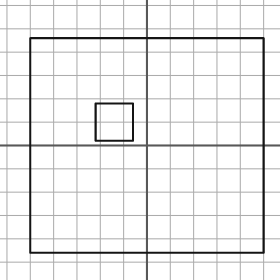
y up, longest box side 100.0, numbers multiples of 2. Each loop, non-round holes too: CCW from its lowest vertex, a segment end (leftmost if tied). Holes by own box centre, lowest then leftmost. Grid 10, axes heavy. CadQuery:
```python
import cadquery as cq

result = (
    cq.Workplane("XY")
    .moveTo(-50.0, -46.0)
    .lineTo(50.0, -46.0)
    .lineTo(50.0, 46.0)
    .lineTo(-50.0, 46.0)
    .close()
    .moveTo(-22.0, 2.0)
    .lineTo(-6.0, 2.0)
    .lineTo(-6.0, 18.0)
    .lineTo(-22.0, 18.0)
    .close()
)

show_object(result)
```